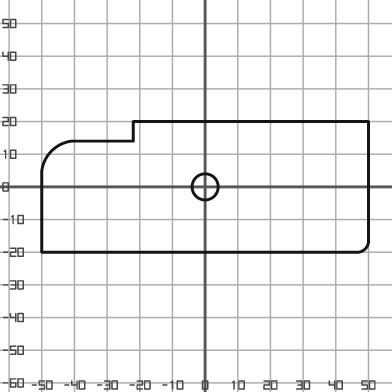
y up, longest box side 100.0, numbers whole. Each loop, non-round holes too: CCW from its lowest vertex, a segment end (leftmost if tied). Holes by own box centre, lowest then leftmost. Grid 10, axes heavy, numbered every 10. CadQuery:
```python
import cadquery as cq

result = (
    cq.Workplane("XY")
    .moveTo(-50.0, -20.0)
    .lineTo(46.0, -20.0)
    .threePointArc((49.0, -19.0), (50.0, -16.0))
    .lineTo(50.0, 20.0)
    .lineTo(-22.0, 20.0)
    .lineTo(-22.0, 14.0)
    .lineTo(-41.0, 14.0)
    .threePointArc((-47.0, 11.0), (-50.0, 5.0))
    .close()
    .moveTo(0.0, 0.0)
    .circle(4.0)
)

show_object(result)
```